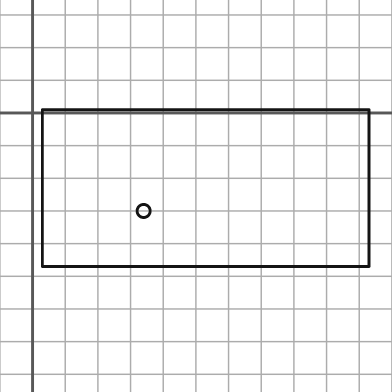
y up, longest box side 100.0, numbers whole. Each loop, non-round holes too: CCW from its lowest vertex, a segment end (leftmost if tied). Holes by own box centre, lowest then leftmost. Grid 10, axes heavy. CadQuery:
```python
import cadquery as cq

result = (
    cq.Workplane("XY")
    .moveTo(3.0, -47.0)
    .lineTo(103.0, -47.0)
    .lineTo(103.0, 1.0)
    .lineTo(3.0, 1.0)
    .close()
    .moveTo(34.0, -30.0)
    .circle(2.0)
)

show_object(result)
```